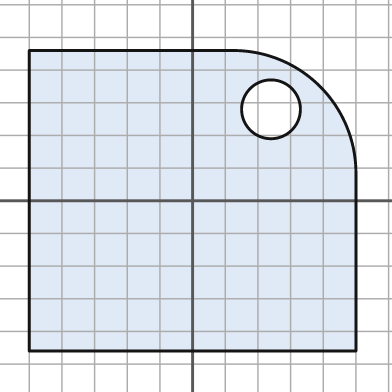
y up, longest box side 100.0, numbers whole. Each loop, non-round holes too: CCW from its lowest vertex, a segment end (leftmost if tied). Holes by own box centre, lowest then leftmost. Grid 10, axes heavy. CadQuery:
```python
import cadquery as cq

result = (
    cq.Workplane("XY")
    .moveTo(-50.0, -46.0)
    .lineTo(50.0, -46.0)
    .lineTo(50.0, 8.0)
    .threePointArc((39.0, 35.0), (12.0, 46.0))
    .lineTo(-50.0, 46.0)
    .close()
    .moveTo(24.0, 28.0)
    .circle(9.0)
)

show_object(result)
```